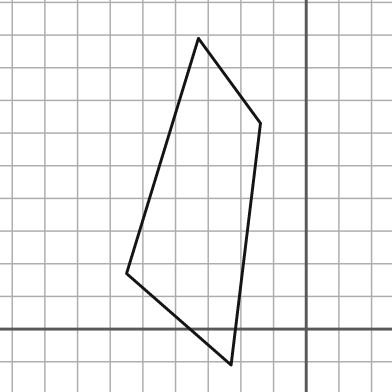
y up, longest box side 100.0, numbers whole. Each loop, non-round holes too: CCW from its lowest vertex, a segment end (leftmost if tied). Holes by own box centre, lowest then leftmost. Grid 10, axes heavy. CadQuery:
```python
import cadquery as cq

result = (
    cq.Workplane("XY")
    .moveTo(-23.0, -11.0)
    .lineTo(-14.0, 63.0)
    .lineTo(-33.0, 89.0)
    .lineTo(-55.0, 17.0)
    .close()
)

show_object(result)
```